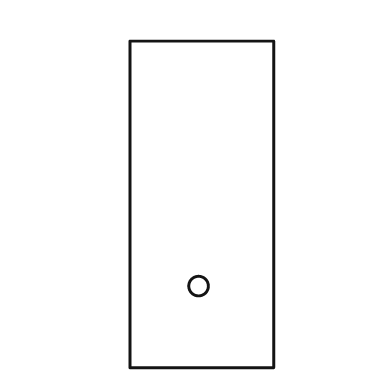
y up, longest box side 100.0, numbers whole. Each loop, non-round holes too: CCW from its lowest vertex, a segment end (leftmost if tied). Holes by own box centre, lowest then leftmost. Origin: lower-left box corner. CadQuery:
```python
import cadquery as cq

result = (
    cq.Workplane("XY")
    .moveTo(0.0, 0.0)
    .lineTo(44.0, 0.0)
    .lineTo(44.0, 100.0)
    .lineTo(0.0, 100.0)
    .close()
    .moveTo(21.0, 25.0)
    .circle(3.0)
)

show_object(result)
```